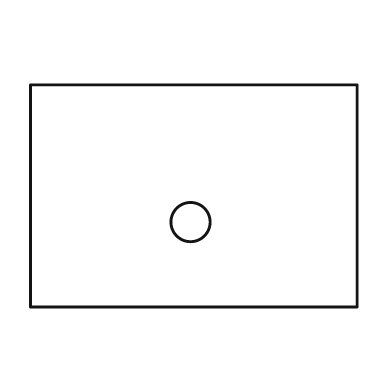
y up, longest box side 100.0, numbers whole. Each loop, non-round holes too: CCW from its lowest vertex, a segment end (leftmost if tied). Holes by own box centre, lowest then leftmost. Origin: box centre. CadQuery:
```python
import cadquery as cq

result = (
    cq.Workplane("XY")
    .moveTo(-50.0, -34.0)
    .lineTo(50.0, -34.0)
    .lineTo(50.0, 34.0)
    .lineTo(-50.0, 34.0)
    .close()
    .moveTo(-1.0, -8.0)
    .circle(6.0)
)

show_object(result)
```